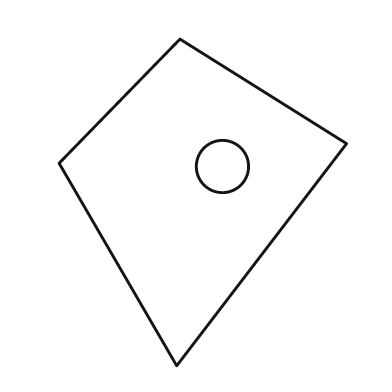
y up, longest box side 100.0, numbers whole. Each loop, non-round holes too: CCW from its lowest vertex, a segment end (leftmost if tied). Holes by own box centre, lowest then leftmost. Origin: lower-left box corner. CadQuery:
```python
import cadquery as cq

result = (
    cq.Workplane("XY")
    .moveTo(36.0, 0.0)
    .lineTo(88.0, 68.0)
    .lineTo(37.0, 100.0)
    .lineTo(0.0, 62.0)
    .close()
    .moveTo(50.0, 61.0)
    .circle(8.0)
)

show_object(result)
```